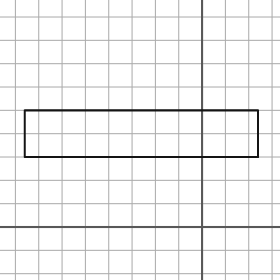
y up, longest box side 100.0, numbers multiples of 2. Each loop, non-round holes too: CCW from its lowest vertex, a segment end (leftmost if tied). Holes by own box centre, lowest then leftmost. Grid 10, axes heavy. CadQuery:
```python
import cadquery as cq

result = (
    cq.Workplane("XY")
    .moveTo(-76.0, 30.0)
    .lineTo(24.0, 30.0)
    .lineTo(24.0, 50.0)
    .lineTo(-76.0, 50.0)
    .close()
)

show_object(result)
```